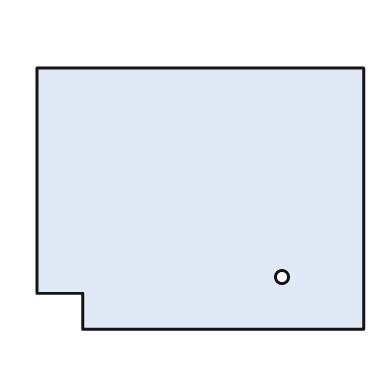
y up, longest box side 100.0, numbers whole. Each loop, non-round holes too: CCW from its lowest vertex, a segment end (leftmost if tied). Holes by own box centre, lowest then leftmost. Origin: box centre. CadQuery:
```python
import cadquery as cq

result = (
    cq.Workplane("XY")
    .moveTo(-36.0, -40.0)
    .lineTo(50.0, -40.0)
    .lineTo(50.0, 40.0)
    .lineTo(-50.0, 40.0)
    .lineTo(-50.0, -29.0)
    .lineTo(-36.0, -29.0)
    .close()
    .moveTo(25.0, -24.0)
    .circle(2.0)
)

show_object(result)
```